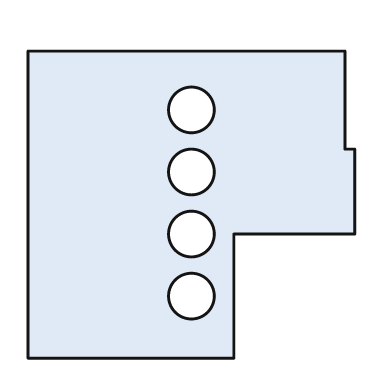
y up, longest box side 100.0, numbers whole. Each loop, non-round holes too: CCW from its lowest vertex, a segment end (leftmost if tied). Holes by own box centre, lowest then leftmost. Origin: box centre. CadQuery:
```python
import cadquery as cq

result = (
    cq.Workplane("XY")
    .moveTo(-50.0, -47.0)
    .lineTo(13.0, -47.0)
    .lineTo(13.0, -9.0)
    .lineTo(50.0, -9.0)
    .lineTo(50.0, 17.0)
    .lineTo(47.0, 17.0)
    .lineTo(47.0, 47.0)
    .lineTo(-50.0, 47.0)
    .close()
    .moveTo(0.0, -28.0)
    .circle(7.0)
    .moveTo(0.0, -9.0)
    .circle(7.0)
    .moveTo(0.0, 10.0)
    .circle(7.0)
    .moveTo(0.0, 29.0)
    .circle(7.0)
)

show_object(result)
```